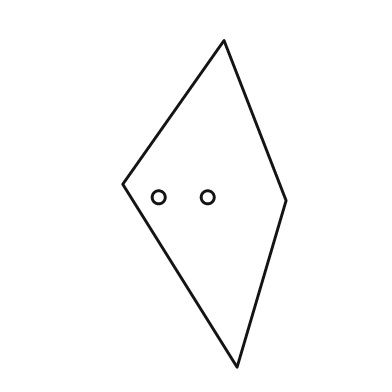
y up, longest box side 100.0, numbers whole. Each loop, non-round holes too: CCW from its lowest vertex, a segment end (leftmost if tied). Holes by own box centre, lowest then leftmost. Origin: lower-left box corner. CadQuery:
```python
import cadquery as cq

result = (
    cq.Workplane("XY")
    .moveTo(35.0, 0.0)
    .lineTo(50.0, 51.0)
    .lineTo(31.0, 100.0)
    .lineTo(0.0, 56.0)
    .close()
    .moveTo(11.0, 52.0)
    .circle(2.0)
    .moveTo(26.0, 52.0)
    .circle(2.0)
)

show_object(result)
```